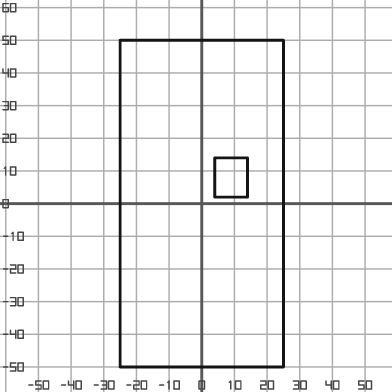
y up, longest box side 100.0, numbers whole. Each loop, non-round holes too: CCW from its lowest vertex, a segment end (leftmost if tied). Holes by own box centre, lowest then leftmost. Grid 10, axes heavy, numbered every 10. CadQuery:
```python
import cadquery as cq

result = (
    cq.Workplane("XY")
    .moveTo(-25.0, -50.0)
    .lineTo(25.0, -50.0)
    .lineTo(25.0, 50.0)
    .lineTo(-25.0, 50.0)
    .close()
    .moveTo(4.0, 2.0)
    .lineTo(14.0, 2.0)
    .lineTo(14.0, 14.0)
    .lineTo(4.0, 14.0)
    .close()
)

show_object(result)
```